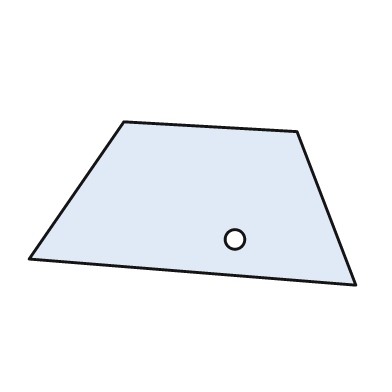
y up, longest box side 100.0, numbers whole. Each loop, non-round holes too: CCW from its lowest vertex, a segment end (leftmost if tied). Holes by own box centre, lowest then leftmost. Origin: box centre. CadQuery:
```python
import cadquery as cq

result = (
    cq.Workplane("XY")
    .moveTo(50.0, -25.0)
    .lineTo(32.0, 22.0)
    .lineTo(-21.0, 25.0)
    .lineTo(-50.0, -17.0)
    .close()
    .moveTo(13.0, -11.0)
    .circle(3.0)
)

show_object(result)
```